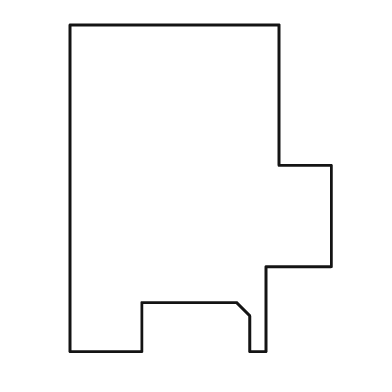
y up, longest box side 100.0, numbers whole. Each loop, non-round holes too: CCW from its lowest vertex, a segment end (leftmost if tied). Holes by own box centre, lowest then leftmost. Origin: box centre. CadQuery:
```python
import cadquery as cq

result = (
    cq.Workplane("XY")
    .moveTo(-40.0, -50.0)
    .lineTo(-18.0, -50.0)
    .lineTo(-18.0, -35.0)
    .lineTo(11.0, -35.0)
    .lineTo(15.0, -39.0)
    .lineTo(15.0, -50.0)
    .lineTo(20.0, -50.0)
    .lineTo(20.0, -24.0)
    .lineTo(40.0, -24.0)
    .lineTo(40.0, 7.0)
    .lineTo(24.0, 7.0)
    .lineTo(24.0, 50.0)
    .lineTo(-40.0, 50.0)
    .close()
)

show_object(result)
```